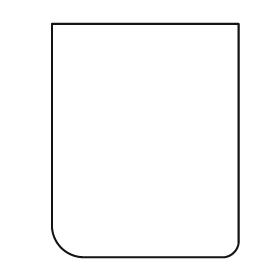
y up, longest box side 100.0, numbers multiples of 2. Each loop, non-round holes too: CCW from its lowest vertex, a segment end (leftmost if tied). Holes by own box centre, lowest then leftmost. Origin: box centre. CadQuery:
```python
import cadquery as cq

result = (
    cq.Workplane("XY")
    .moveTo(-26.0, -50.0)
    .lineTo(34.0, -50.0)
    .threePointArc((38.0, -48.0), (40.0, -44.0))
    .lineTo(40.0, 50.0)
    .lineTo(-40.0, 50.0)
    .lineTo(-40.0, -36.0)
    .threePointArc((-36.0, -46.0), (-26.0, -50.0))
    .close()
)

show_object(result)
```